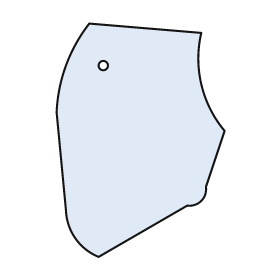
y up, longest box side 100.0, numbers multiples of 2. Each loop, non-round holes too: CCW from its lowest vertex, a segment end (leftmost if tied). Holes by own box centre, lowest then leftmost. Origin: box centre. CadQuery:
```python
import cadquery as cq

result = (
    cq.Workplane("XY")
    .moveTo(-18.0, -50.0)
    .lineTo(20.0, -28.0)
    .threePointArc((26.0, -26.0), (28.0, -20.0))
    .lineTo(36.0, 4.0)
    .threePointArc((26.0, 24.0), (26.0, 46.0))
    .lineTo(-22.0, 50.0)
    .threePointArc((-32.0, 32.0), (-36.0, 12.0))
    .lineTo(-32.0, -30.0)
    .threePointArc((-28.0, -42.0), (-18.0, -50.0))
    .close()
    .moveTo(-16.0, 32.0)
    .circle(2.0)
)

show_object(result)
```